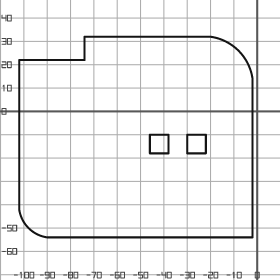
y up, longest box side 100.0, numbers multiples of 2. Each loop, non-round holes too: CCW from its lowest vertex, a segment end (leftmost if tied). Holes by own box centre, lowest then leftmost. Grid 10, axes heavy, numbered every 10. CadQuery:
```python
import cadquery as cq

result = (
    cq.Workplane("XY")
    .moveTo(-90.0, -54.0)
    .lineTo(-2.0, -54.0)
    .lineTo(-2.0, 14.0)
    .threePointArc((-8.0, 26.0), (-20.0, 32.0))
    .lineTo(-74.0, 32.0)
    .lineTo(-74.0, 22.0)
    .lineTo(-102.0, 22.0)
    .lineTo(-102.0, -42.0)
    .threePointArc((-98.0, -50.0), (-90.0, -54.0))
    .close()
    .moveTo(-46.0, -18.0)
    .lineTo(-38.0, -18.0)
    .lineTo(-38.0, -10.0)
    .lineTo(-46.0, -10.0)
    .close()
    .moveTo(-30.0, -18.0)
    .lineTo(-22.0, -18.0)
    .lineTo(-22.0, -10.0)
    .lineTo(-30.0, -10.0)
    .close()
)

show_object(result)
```